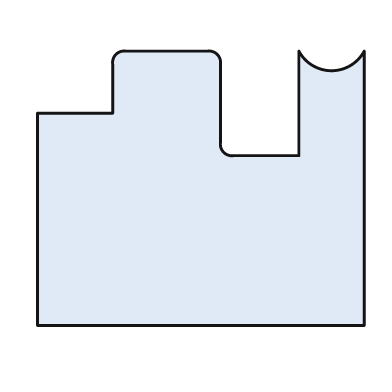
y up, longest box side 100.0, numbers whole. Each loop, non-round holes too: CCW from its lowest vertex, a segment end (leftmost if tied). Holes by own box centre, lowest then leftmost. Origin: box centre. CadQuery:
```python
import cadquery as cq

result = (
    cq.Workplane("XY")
    .moveTo(-50.0, -42.0)
    .lineTo(50.0, -42.0)
    .lineTo(50.0, 42.0)
    .threePointArc((40.0, 36.0), (30.0, 42.0))
    .lineTo(30.0, 10.0)
    .lineTo(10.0, 10.0)
    .threePointArc((7.0, 11.0), (6.0, 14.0))
    .lineTo(6.0, 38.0)
    .threePointArc((5.0, 41.0), (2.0, 42.0))
    .lineTo(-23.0, 42.0)
    .threePointArc((-26.0, 41.0), (-27.0, 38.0))
    .lineTo(-27.0, 23.0)
    .lineTo(-50.0, 23.0)
    .close()
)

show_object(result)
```